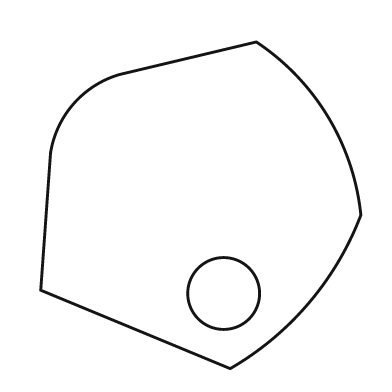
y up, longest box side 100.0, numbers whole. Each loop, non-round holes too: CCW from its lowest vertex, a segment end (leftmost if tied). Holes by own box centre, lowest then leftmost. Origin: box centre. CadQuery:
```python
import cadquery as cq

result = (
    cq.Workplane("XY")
    .moveTo(9.0, -50.0)
    .threePointArc((33.0, -30.0), (49.0, -3.0))
    .threePointArc((39.0, 27.0), (17.0, 50.0))
    .lineTo(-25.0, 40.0)
    .threePointArc((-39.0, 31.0), (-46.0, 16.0))
    .lineTo(-49.0, -26.0)
    .close()
    .moveTo(7.0, -27.0)
    .circle(11.0)
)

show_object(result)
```